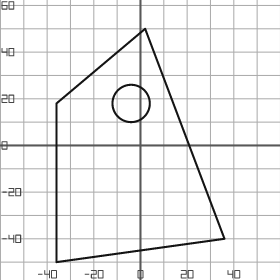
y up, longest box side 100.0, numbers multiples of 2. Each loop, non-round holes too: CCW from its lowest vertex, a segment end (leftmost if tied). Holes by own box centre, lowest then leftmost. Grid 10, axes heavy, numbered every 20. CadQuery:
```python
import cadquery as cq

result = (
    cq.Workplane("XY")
    .moveTo(-36.0, -50.0)
    .lineTo(36.0, -40.0)
    .lineTo(2.0, 50.0)
    .lineTo(-36.0, 18.0)
    .close()
    .moveTo(-4.0, 18.0)
    .circle(8.0)
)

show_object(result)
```